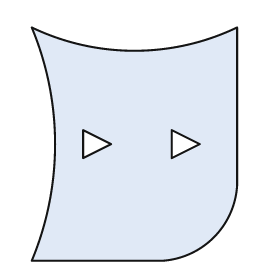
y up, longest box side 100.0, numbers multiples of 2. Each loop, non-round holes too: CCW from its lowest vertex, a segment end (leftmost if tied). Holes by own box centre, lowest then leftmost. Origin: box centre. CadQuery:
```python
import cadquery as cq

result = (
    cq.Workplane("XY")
    .moveTo(-44.0, -50.0)
    .lineTo(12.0, -50.0)
    .threePointArc((34.0, -40.0), (44.0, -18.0))
    .lineTo(44.0, 50.0)
    .threePointArc((0.0, 40.0), (-44.0, 50.0))
    .threePointArc((-34.0, 0.0), (-44.0, -50.0))
    .close()
    .moveTo(-22.0, -6.0)
    .lineTo(-10.0, 0.0)
    .lineTo(-22.0, 6.0)
    .close()
    .moveTo(16.0, -6.0)
    .lineTo(28.0, 0.0)
    .lineTo(16.0, 6.0)
    .close()
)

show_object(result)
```